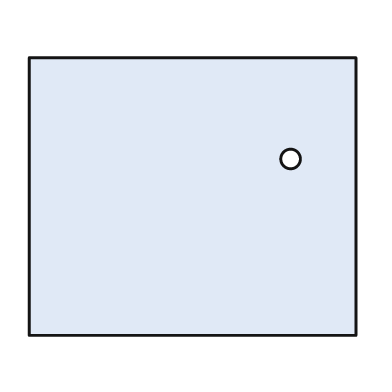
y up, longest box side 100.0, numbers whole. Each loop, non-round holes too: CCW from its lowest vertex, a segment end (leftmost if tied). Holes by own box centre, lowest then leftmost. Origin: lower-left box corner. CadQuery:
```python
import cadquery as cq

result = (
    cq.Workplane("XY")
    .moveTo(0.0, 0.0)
    .lineTo(100.0, 0.0)
    .lineTo(100.0, 85.0)
    .lineTo(0.0, 85.0)
    .close()
    .moveTo(80.0, 54.0)
    .circle(3.0)
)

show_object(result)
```